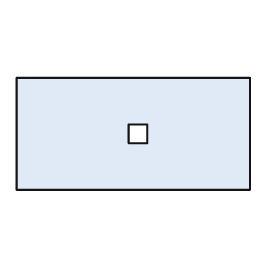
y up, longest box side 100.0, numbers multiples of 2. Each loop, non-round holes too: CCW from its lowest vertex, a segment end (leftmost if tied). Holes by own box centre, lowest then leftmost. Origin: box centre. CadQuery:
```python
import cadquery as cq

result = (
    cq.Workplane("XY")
    .moveTo(-50.0, -24.0)
    .lineTo(50.0, -24.0)
    .lineTo(50.0, 24.0)
    .lineTo(-50.0, 24.0)
    .close()
    .moveTo(-2.0, -4.0)
    .lineTo(6.0, -4.0)
    .lineTo(6.0, 4.0)
    .lineTo(-2.0, 4.0)
    .close()
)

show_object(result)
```